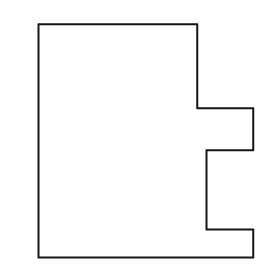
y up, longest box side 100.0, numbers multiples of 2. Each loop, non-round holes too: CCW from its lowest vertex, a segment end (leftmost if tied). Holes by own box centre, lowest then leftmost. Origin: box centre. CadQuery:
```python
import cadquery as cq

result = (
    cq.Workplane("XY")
    .moveTo(-46.0, -50.0)
    .lineTo(46.0, -50.0)
    .lineTo(46.0, -38.0)
    .lineTo(26.0, -38.0)
    .lineTo(26.0, -4.0)
    .lineTo(46.0, -4.0)
    .lineTo(46.0, 14.0)
    .lineTo(22.0, 14.0)
    .lineTo(22.0, 50.0)
    .lineTo(-46.0, 50.0)
    .close()
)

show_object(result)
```